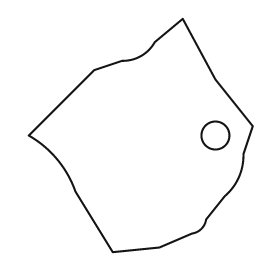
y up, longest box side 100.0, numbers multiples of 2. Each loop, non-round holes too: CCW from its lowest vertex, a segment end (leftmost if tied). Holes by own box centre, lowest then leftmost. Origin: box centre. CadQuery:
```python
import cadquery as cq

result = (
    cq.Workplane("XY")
    .moveTo(-12.0, -50.0)
    .lineTo(8.0, -48.0)
    .lineTo(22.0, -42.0)
    .threePointArc((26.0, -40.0), (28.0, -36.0))
    .lineTo(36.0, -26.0)
    .threePointArc((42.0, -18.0), (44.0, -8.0))
    .lineTo(48.0, 4.0)
    .lineTo(32.0, 24.0)
    .lineTo(18.0, 50.0)
    .lineTo(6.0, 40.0)
    .threePointArc((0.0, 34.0), (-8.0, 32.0))
    .lineTo(-20.0, 28.0)
    .lineTo(-48.0, 0.0)
    .threePointArc((-36.0, -10.0), (-28.0, -24.0))
    .close()
    .moveTo(32.0, 0.0)
    .circle(6.0)
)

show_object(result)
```